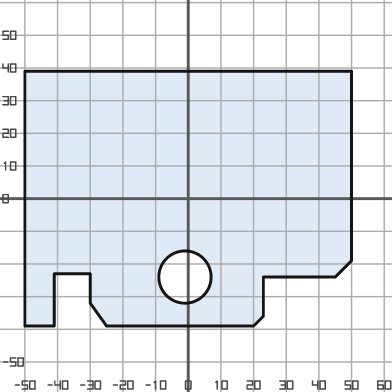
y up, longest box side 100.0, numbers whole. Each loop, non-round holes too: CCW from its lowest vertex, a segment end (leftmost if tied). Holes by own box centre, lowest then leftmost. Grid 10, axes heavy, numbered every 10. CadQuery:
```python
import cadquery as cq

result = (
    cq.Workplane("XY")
    .moveTo(-50.0, -39.0)
    .lineTo(-41.0, -39.0)
    .lineTo(-41.0, -23.0)
    .lineTo(-30.0, -23.0)
    .lineTo(-30.0, -32.0)
    .lineTo(-25.0, -39.0)
    .lineTo(20.0, -39.0)
    .lineTo(23.0, -36.0)
    .lineTo(23.0, -24.0)
    .lineTo(45.0, -24.0)
    .lineTo(50.0, -19.0)
    .lineTo(50.0, 39.0)
    .lineTo(-50.0, 39.0)
    .close()
    .moveTo(-1.0, -24.0)
    .circle(8.0)
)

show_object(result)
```